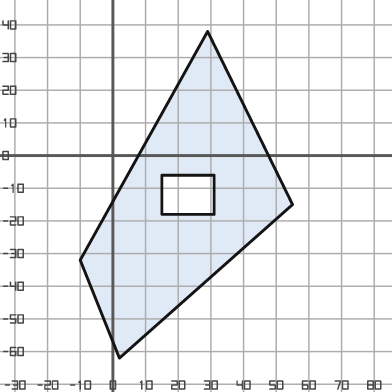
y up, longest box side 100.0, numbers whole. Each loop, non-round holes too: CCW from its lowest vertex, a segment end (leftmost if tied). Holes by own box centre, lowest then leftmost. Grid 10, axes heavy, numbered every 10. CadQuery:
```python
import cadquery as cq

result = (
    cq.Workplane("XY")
    .moveTo(2.0, -62.0)
    .lineTo(55.0, -15.0)
    .lineTo(29.0, 38.0)
    .lineTo(-10.0, -32.0)
    .close()
    .moveTo(15.0, -18.0)
    .lineTo(31.0, -18.0)
    .lineTo(31.0, -6.0)
    .lineTo(15.0, -6.0)
    .close()
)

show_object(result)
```